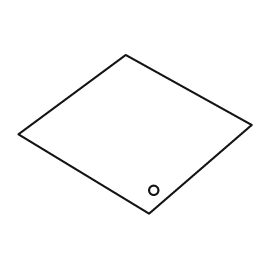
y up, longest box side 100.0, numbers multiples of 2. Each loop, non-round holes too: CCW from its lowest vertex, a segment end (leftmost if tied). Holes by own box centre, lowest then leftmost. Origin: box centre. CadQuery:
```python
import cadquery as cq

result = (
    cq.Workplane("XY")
    .moveTo(6.0, -34.0)
    .lineTo(50.0, 4.0)
    .lineTo(-4.0, 34.0)
    .lineTo(-50.0, 0.0)
    .close()
    .moveTo(8.0, -24.0)
    .circle(2.0)
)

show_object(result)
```